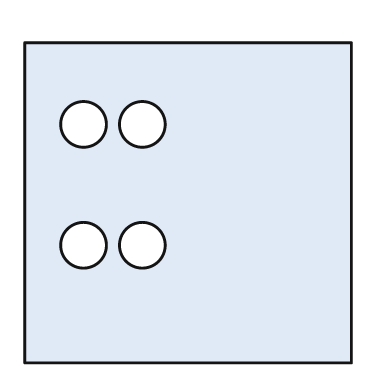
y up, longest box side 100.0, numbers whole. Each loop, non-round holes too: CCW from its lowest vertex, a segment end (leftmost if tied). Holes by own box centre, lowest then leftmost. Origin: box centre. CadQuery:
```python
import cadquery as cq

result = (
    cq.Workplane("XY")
    .moveTo(-50.0, -49.0)
    .lineTo(50.0, -49.0)
    .lineTo(50.0, 49.0)
    .lineTo(-50.0, 49.0)
    .close()
    .moveTo(-32.0, -13.0)
    .circle(7.0)
    .moveTo(-14.0, -13.0)
    .circle(7.0)
    .moveTo(-32.0, 24.0)
    .circle(7.0)
    .moveTo(-14.0, 24.0)
    .circle(7.0)
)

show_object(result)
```